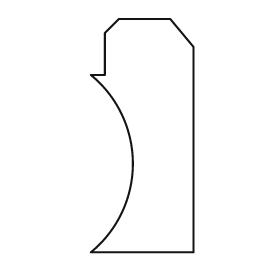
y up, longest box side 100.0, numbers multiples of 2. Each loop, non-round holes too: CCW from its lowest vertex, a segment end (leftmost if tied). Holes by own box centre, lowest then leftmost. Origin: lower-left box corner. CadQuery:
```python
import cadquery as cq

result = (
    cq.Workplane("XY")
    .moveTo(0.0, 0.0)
    .lineTo(44.0, 0.0)
    .lineTo(44.0, 88.0)
    .lineTo(34.0, 100.0)
    .lineTo(12.0, 100.0)
    .lineTo(6.0, 94.0)
    .lineTo(6.0, 76.0)
    .lineTo(0.0, 76.0)
    .threePointArc((18.0, 38.0), (0.0, 0.0))
    .close()
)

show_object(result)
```